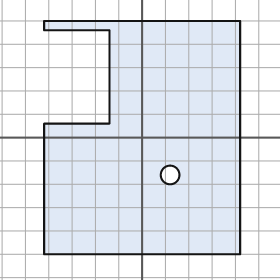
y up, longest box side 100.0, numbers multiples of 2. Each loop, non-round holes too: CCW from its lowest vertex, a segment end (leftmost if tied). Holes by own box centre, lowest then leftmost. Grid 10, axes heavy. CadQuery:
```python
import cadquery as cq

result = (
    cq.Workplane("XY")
    .moveTo(-42.0, -50.0)
    .lineTo(42.0, -50.0)
    .lineTo(42.0, 50.0)
    .lineTo(-42.0, 50.0)
    .lineTo(-42.0, 46.0)
    .lineTo(-14.0, 46.0)
    .lineTo(-14.0, 6.0)
    .lineTo(-42.0, 6.0)
    .close()
    .moveTo(12.0, -16.0)
    .circle(4.0)
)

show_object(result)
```